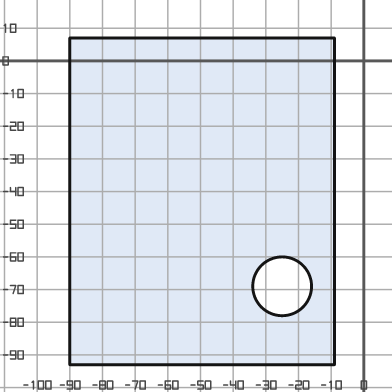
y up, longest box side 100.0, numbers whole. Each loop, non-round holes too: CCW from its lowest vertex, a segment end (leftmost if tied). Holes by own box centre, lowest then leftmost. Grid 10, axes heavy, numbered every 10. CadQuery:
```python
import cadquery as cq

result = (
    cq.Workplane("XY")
    .moveTo(-90.0, -93.0)
    .lineTo(-9.0, -93.0)
    .lineTo(-9.0, 7.0)
    .lineTo(-90.0, 7.0)
    .close()
    .moveTo(-25.0, -69.0)
    .circle(9.0)
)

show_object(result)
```